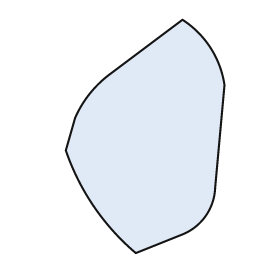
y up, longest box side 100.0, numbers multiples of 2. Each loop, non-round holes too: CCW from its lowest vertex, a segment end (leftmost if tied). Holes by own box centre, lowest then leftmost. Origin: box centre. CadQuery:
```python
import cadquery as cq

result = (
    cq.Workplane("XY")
    .moveTo(-4.0, -50.0)
    .lineTo(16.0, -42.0)
    .threePointArc((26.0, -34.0), (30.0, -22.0))
    .lineTo(34.0, 22.0)
    .threePointArc((28.0, 38.0), (16.0, 50.0))
    .lineTo(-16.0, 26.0)
    .threePointArc((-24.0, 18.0), (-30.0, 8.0))
    .lineTo(-34.0, -6.0)
    .threePointArc((-22.0, -30.0), (-4.0, -50.0))
    .close()
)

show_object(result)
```